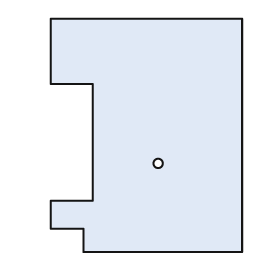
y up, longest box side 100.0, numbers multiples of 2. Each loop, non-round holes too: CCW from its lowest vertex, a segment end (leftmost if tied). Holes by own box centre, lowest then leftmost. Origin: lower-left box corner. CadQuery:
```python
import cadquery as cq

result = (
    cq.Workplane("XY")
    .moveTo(14.0, 0.0)
    .lineTo(82.0, 0.0)
    .lineTo(82.0, 100.0)
    .lineTo(0.0, 100.0)
    .lineTo(0.0, 72.0)
    .lineTo(18.0, 72.0)
    .lineTo(18.0, 22.0)
    .lineTo(0.0, 22.0)
    .lineTo(0.0, 10.0)
    .lineTo(14.0, 10.0)
    .close()
    .moveTo(46.0, 38.0)
    .circle(2.0)
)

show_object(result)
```